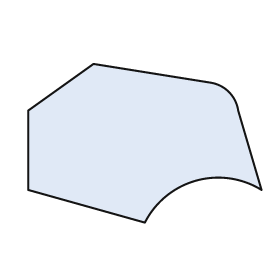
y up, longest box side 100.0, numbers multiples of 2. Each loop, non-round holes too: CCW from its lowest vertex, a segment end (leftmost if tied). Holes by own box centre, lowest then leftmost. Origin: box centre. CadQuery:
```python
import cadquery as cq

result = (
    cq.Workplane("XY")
    .moveTo(0.0, -34.0)
    .threePointArc((22.0, -16.0), (50.0, -20.0))
    .lineTo(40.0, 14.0)
    .threePointArc((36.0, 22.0), (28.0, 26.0))
    .lineTo(-22.0, 34.0)
    .lineTo(-50.0, 14.0)
    .lineTo(-50.0, -20.0)
    .close()
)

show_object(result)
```